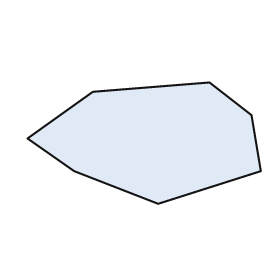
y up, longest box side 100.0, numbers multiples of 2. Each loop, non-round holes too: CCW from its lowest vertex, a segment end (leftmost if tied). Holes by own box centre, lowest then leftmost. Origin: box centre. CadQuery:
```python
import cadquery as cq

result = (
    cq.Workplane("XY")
    .moveTo(6.0, -26.0)
    .lineTo(50.0, -12.0)
    .lineTo(46.0, 12.0)
    .lineTo(28.0, 26.0)
    .lineTo(-22.0, 22.0)
    .lineTo(-50.0, 2.0)
    .lineTo(-30.0, -12.0)
    .close()
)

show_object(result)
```